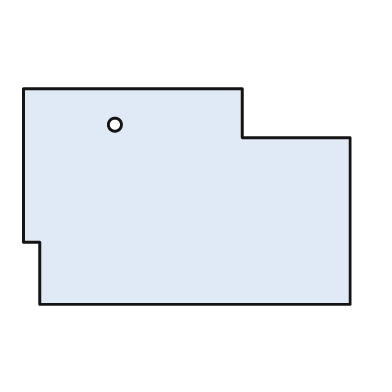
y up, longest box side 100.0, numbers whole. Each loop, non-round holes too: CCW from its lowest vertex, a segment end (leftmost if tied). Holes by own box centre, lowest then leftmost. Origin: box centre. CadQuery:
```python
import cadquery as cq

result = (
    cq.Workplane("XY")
    .moveTo(-45.0, -33.0)
    .lineTo(50.0, -33.0)
    .lineTo(50.0, 18.0)
    .lineTo(17.0, 18.0)
    .lineTo(17.0, 33.0)
    .lineTo(-50.0, 33.0)
    .lineTo(-50.0, -14.0)
    .lineTo(-45.0, -14.0)
    .close()
    .moveTo(-22.0, 22.0)
    .circle(2.0)
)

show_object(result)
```